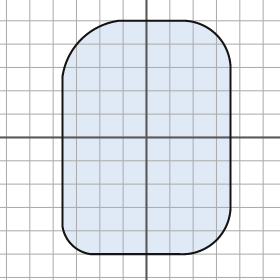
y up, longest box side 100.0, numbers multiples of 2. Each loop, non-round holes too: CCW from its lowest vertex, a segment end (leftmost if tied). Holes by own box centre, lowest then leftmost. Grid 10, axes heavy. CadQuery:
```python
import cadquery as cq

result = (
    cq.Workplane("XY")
    .moveTo(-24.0, -50.0)
    .lineTo(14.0, -50.0)
    .threePointArc((30.0, -44.0), (36.0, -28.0))
    .lineTo(36.0, 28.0)
    .threePointArc((30.0, 44.0), (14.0, 50.0))
    .lineTo(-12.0, 50.0)
    .threePointArc((-28.0, 42.0), (-36.0, 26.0))
    .lineTo(-36.0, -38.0)
    .threePointArc((-32.0, -46.0), (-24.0, -50.0))
    .close()
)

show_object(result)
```